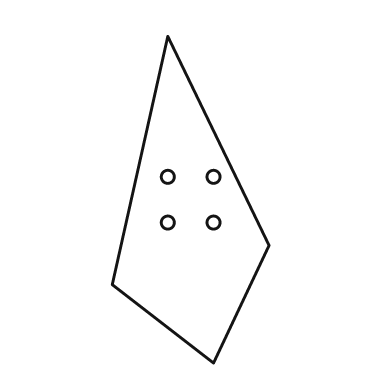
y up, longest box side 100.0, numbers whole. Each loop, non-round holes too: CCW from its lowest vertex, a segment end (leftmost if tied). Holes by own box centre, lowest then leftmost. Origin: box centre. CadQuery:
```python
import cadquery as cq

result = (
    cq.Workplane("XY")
    .moveTo(7.0, -50.0)
    .lineTo(24.0, -14.0)
    .lineTo(-7.0, 50.0)
    .lineTo(-24.0, -26.0)
    .close()
    .moveTo(-7.0, -7.0)
    .circle(2.0)
    .moveTo(7.0, -7.0)
    .circle(2.0)
    .moveTo(-7.0, 7.0)
    .circle(2.0)
    .moveTo(7.0, 7.0)
    .circle(2.0)
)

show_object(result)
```